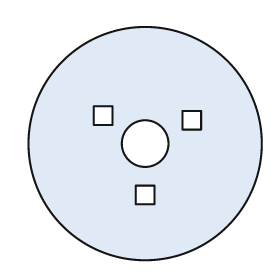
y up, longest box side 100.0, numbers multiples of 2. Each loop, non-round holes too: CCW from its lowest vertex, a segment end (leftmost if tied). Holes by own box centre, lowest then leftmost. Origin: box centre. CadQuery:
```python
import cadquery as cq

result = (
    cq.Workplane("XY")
    .moveTo(0.0, 0.0)
    .circle(50.0)
    .moveTo(-4.0, -26.0)
    .lineTo(4.0, -26.0)
    .lineTo(4.0, -18.0)
    .lineTo(-4.0, -18.0)
    .close()
    .moveTo(0.0, 0.0)
    .circle(10.0)
    .moveTo(16.0, 6.0)
    .lineTo(24.0, 6.0)
    .lineTo(24.0, 14.0)
    .lineTo(16.0, 14.0)
    .close()
    .moveTo(-22.0, 8.0)
    .lineTo(-14.0, 8.0)
    .lineTo(-14.0, 16.0)
    .lineTo(-22.0, 16.0)
    .close()
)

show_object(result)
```